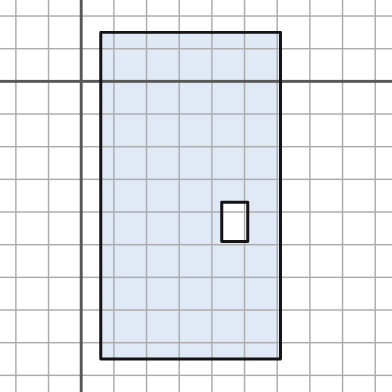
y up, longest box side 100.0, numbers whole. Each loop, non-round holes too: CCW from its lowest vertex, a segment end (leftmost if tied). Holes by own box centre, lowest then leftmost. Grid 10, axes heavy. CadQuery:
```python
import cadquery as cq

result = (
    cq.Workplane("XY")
    .moveTo(6.0, -85.0)
    .lineTo(61.0, -85.0)
    .lineTo(61.0, 15.0)
    .lineTo(6.0, 15.0)
    .close()
    .moveTo(43.0, -49.0)
    .lineTo(51.0, -49.0)
    .lineTo(51.0, -37.0)
    .lineTo(43.0, -37.0)
    .close()
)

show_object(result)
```